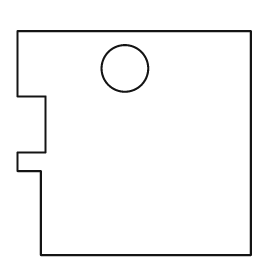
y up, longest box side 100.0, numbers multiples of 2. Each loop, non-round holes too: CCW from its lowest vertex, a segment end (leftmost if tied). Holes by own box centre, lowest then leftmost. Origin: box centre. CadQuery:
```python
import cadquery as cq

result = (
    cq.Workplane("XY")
    .moveTo(-40.0, -48.0)
    .lineTo(50.0, -48.0)
    .lineTo(50.0, 48.0)
    .lineTo(-50.0, 48.0)
    .lineTo(-50.0, 20.0)
    .lineTo(-38.0, 20.0)
    .lineTo(-38.0, -4.0)
    .lineTo(-50.0, -4.0)
    .lineTo(-50.0, -12.0)
    .lineTo(-40.0, -12.0)
    .close()
    .moveTo(-4.0, 32.0)
    .circle(10.0)
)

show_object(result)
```